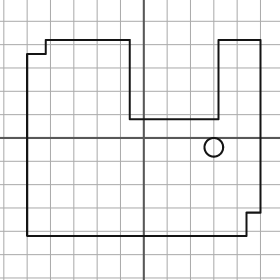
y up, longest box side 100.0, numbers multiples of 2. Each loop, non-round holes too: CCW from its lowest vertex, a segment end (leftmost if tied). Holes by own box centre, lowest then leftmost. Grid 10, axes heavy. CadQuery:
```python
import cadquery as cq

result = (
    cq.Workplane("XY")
    .moveTo(-50.0, -42.0)
    .lineTo(44.0, -42.0)
    .lineTo(44.0, -32.0)
    .lineTo(50.0, -32.0)
    .lineTo(50.0, 42.0)
    .lineTo(32.0, 42.0)
    .lineTo(32.0, 8.0)
    .lineTo(-6.0, 8.0)
    .lineTo(-6.0, 42.0)
    .lineTo(-42.0, 42.0)
    .lineTo(-42.0, 36.0)
    .lineTo(-50.0, 36.0)
    .close()
    .moveTo(30.0, -4.0)
    .circle(4.0)
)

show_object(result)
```